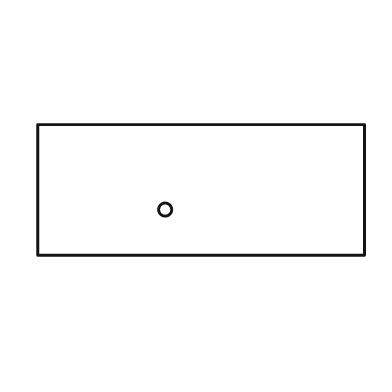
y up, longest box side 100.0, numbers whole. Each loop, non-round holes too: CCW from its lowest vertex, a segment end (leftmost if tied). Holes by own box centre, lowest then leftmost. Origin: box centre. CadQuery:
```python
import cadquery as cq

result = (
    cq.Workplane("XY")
    .moveTo(-50.0, -20.0)
    .lineTo(50.0, -20.0)
    .lineTo(50.0, 20.0)
    .lineTo(-50.0, 20.0)
    .close()
    .moveTo(-11.0, -6.0)
    .circle(2.0)
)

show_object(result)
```